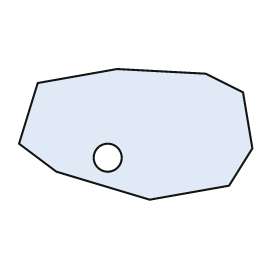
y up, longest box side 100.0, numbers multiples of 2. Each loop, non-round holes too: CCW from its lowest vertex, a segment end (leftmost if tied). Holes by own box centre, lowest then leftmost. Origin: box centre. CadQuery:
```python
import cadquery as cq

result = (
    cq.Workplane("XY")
    .moveTo(6.0, -28.0)
    .lineTo(40.0, -22.0)
    .lineTo(50.0, -6.0)
    .lineTo(46.0, 18.0)
    .lineTo(30.0, 26.0)
    .lineTo(-8.0, 28.0)
    .lineTo(-42.0, 22.0)
    .lineTo(-50.0, -4.0)
    .lineTo(-34.0, -16.0)
    .close()
    .moveTo(-12.0, -10.0)
    .circle(6.0)
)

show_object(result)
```